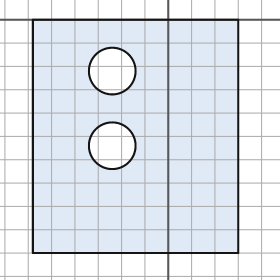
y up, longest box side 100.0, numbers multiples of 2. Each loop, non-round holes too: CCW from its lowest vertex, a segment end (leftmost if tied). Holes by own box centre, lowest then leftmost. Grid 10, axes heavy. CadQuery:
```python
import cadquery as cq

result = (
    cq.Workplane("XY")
    .moveTo(-58.0, -100.0)
    .lineTo(30.0, -100.0)
    .lineTo(30.0, 0.0)
    .lineTo(-58.0, 0.0)
    .close()
    .moveTo(-24.0, -54.0)
    .circle(10.0)
    .moveTo(-24.0, -22.0)
    .circle(10.0)
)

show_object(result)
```